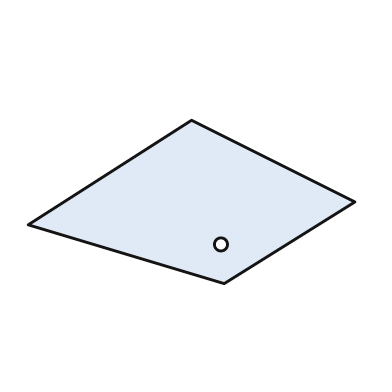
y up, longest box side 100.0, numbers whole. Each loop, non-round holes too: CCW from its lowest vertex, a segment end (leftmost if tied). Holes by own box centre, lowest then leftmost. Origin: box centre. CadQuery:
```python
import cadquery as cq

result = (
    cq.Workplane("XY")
    .moveTo(10.0, -25.0)
    .lineTo(50.0, 0.0)
    .lineTo(0.0, 25.0)
    .lineTo(-50.0, -7.0)
    .close()
    .moveTo(9.0, -13.0)
    .circle(2.0)
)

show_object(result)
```